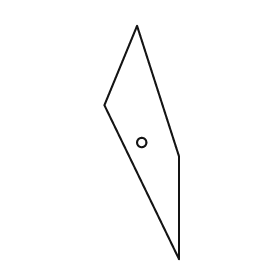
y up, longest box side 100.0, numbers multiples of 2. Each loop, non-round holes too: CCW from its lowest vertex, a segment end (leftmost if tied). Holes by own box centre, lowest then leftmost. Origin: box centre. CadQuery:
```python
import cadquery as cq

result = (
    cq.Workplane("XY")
    .moveTo(16.0, -50.0)
    .lineTo(16.0, -6.0)
    .lineTo(-2.0, 50.0)
    .lineTo(-16.0, 16.0)
    .close()
    .moveTo(0.0, 0.0)
    .circle(2.0)
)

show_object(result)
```